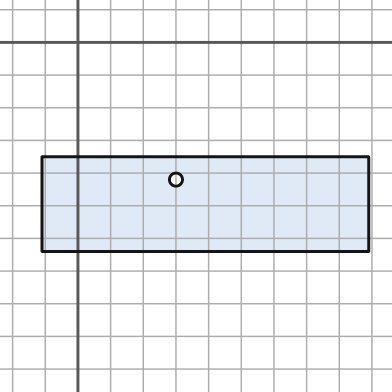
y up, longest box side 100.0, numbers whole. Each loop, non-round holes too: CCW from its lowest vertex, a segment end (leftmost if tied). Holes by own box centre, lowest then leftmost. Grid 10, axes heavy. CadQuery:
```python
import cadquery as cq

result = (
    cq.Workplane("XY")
    .moveTo(-11.0, -64.0)
    .lineTo(89.0, -64.0)
    .lineTo(89.0, -35.0)
    .lineTo(-11.0, -35.0)
    .close()
    .moveTo(30.0, -42.0)
    .circle(2.0)
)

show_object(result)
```